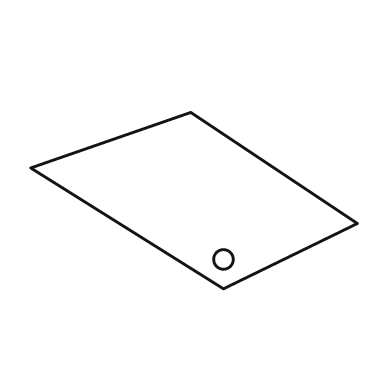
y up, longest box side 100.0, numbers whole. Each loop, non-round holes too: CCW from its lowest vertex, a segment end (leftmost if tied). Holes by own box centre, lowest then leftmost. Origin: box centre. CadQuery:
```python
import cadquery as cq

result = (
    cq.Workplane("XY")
    .moveTo(9.0, -27.0)
    .lineTo(50.0, -7.0)
    .lineTo(-1.0, 27.0)
    .lineTo(-50.0, 10.0)
    .close()
    .moveTo(9.0, -18.0)
    .circle(3.0)
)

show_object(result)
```